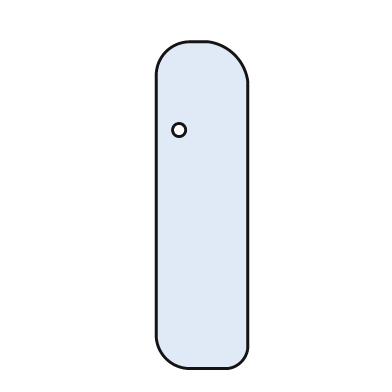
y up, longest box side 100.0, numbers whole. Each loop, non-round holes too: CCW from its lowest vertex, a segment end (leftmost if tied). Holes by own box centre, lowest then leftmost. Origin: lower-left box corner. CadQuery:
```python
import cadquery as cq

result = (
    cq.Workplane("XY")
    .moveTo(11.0, 0.0)
    .lineTo(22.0, 0.0)
    .threePointArc((26.0, 2.0), (28.0, 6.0))
    .lineTo(28.0, 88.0)
    .threePointArc((24.0, 96.0), (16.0, 100.0))
    .lineTo(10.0, 100.0)
    .threePointArc((3.0, 97.0), (0.0, 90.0))
    .lineTo(0.0, 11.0)
    .threePointArc((3.0, 3.0), (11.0, 0.0))
    .close()
    .moveTo(7.0, 73.0)
    .circle(2.0)
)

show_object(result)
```